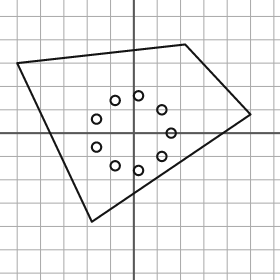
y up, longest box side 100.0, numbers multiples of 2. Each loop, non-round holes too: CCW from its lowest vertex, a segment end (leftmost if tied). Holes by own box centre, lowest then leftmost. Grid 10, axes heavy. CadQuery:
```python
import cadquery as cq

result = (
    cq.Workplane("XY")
    .moveTo(-18.0, -38.0)
    .lineTo(50.0, 8.0)
    .lineTo(22.0, 38.0)
    .lineTo(-50.0, 30.0)
    .close()
    .moveTo(2.0, -16.0)
    .circle(2.0)
    .moveTo(-8.0, -14.0)
    .circle(2.0)
    .moveTo(12.0, -10.0)
    .circle(2.0)
    .moveTo(-16.0, -6.0)
    .circle(2.0)
    .moveTo(16.0, 0.0)
    .circle(2.0)
    .moveTo(-16.0, 6.0)
    .circle(2.0)
    .moveTo(12.0, 10.0)
    .circle(2.0)
    .moveTo(-8.0, 14.0)
    .circle(2.0)
    .moveTo(2.0, 16.0)
    .circle(2.0)
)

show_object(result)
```